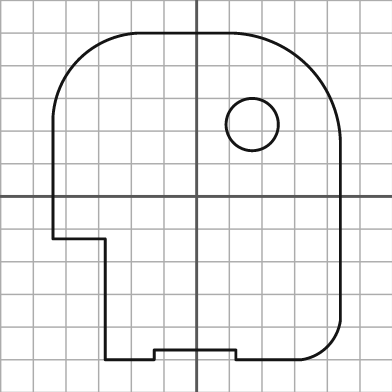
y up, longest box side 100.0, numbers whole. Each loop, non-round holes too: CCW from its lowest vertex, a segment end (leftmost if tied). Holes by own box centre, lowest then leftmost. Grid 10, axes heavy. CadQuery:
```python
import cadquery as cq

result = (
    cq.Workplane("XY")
    .moveTo(-28.0, -50.0)
    .lineTo(-13.0, -50.0)
    .lineTo(-13.0, -47.0)
    .lineTo(12.0, -47.0)
    .lineTo(12.0, -50.0)
    .lineTo(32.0, -50.0)
    .threePointArc((40.0, -46.0), (44.0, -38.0))
    .lineTo(44.0, 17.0)
    .threePointArc((34.0, 40.0), (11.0, 50.0))
    .lineTo(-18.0, 50.0)
    .threePointArc((-36.0, 42.0), (-44.0, 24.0))
    .lineTo(-44.0, -13.0)
    .lineTo(-28.0, -13.0)
    .close()
    .moveTo(17.0, 22.0)
    .circle(8.0)
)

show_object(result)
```